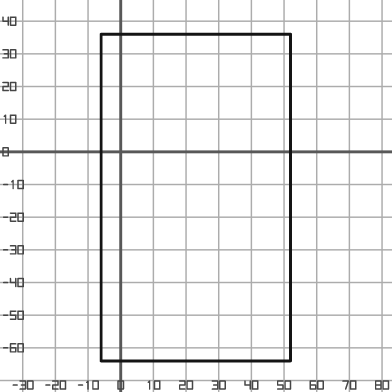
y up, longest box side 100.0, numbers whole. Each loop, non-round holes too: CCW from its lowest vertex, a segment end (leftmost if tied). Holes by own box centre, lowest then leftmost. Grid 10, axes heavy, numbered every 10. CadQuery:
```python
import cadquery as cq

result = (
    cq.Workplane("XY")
    .moveTo(-6.0, -64.0)
    .lineTo(52.0, -64.0)
    .lineTo(52.0, 36.0)
    .lineTo(-6.0, 36.0)
    .close()
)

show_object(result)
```